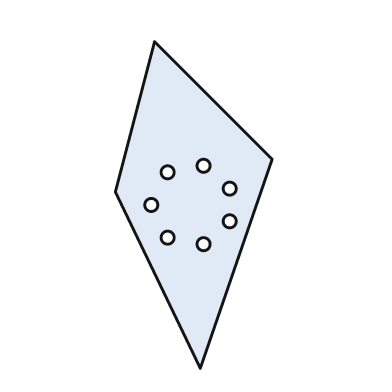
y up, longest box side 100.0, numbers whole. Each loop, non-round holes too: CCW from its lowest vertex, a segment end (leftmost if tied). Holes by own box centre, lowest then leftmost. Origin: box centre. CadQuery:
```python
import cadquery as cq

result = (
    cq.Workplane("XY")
    .moveTo(2.0, -50.0)
    .lineTo(24.0, 14.0)
    .lineTo(-12.0, 50.0)
    .lineTo(-24.0, 4.0)
    .close()
    .moveTo(3.0, -12.0)
    .circle(2.0)
    .moveTo(-8.0, -10.0)
    .circle(2.0)
    .moveTo(11.0, -5.0)
    .circle(2.0)
    .moveTo(-13.0, 0.0)
    .circle(2.0)
    .moveTo(11.0, 5.0)
    .circle(2.0)
    .moveTo(-8.0, 10.0)
    .circle(2.0)
    .moveTo(3.0, 12.0)
    .circle(2.0)
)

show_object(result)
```